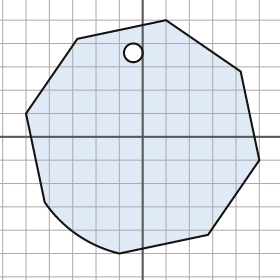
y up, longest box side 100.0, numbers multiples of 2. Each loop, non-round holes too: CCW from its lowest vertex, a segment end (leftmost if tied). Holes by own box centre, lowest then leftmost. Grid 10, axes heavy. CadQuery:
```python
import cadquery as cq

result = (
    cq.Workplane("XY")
    .moveTo(-10.0, -50.0)
    .lineTo(28.0, -42.0)
    .lineTo(50.0, -10.0)
    .lineTo(42.0, 28.0)
    .lineTo(10.0, 50.0)
    .lineTo(-28.0, 42.0)
    .lineTo(-50.0, 10.0)
    .lineTo(-42.0, -28.0)
    .threePointArc((-28.0, -42.0), (-10.0, -50.0))
    .close()
    .moveTo(-4.0, 36.0)
    .circle(4.0)
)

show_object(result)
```